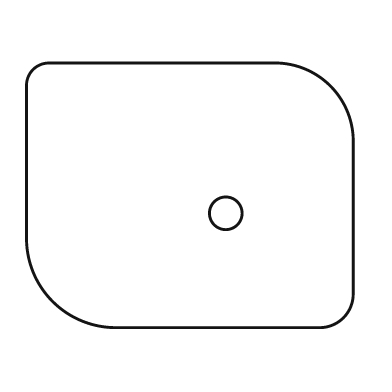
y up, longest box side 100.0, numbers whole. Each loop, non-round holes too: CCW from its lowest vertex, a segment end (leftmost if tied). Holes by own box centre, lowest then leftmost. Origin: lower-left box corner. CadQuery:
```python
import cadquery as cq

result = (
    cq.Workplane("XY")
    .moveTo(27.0, 0.0)
    .lineTo(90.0, 0.0)
    .threePointArc((97.0, 3.0), (100.0, 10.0))
    .lineTo(100.0, 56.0)
    .threePointArc((93.0, 74.0), (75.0, 81.0))
    .lineTo(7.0, 81.0)
    .threePointArc((2.0, 79.0), (0.0, 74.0))
    .lineTo(0.0, 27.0)
    .threePointArc((8.0, 8.0), (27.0, 0.0))
    .close()
    .moveTo(61.0, 35.0)
    .circle(5.0)
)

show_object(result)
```